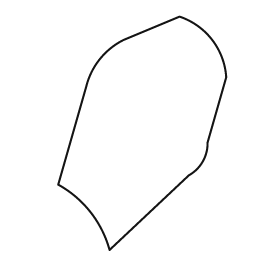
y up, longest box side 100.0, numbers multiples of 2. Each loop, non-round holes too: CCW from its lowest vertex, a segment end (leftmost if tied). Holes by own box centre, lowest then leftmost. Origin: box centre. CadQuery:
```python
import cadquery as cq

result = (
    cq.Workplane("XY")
    .moveTo(-14.0, -50.0)
    .lineTo(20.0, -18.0)
    .threePointArc((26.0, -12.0), (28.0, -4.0))
    .lineTo(36.0, 24.0)
    .threePointArc((30.0, 40.0), (16.0, 50.0))
    .lineTo(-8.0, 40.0)
    .threePointArc((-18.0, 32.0), (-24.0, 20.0))
    .lineTo(-36.0, -22.0)
    .threePointArc((-22.0, -34.0), (-14.0, -50.0))
    .close()
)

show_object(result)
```